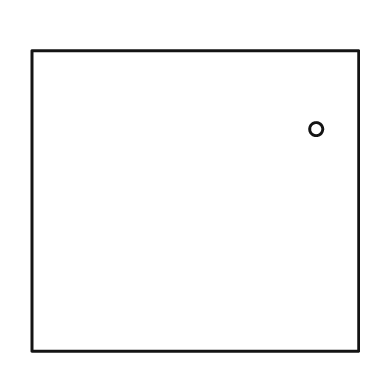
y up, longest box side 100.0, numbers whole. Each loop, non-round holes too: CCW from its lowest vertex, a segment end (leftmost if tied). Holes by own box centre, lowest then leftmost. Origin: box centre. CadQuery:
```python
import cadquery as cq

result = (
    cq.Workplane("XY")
    .moveTo(-50.0, -46.0)
    .lineTo(50.0, -46.0)
    .lineTo(50.0, 46.0)
    .lineTo(-50.0, 46.0)
    .close()
    .moveTo(37.0, 22.0)
    .circle(2.0)
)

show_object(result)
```